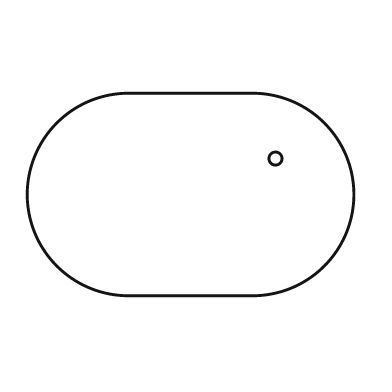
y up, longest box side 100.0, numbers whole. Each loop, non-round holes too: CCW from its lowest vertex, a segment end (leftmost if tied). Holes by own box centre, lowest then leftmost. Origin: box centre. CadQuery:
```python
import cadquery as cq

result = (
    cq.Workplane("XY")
    .moveTo(-19.0, -31.0)
    .lineTo(19.0, -31.0)
    .threePointArc((50.0, 0.0), (19.0, 31.0))
    .lineTo(-19.0, 31.0)
    .threePointArc((-50.0, 0.0), (-19.0, -31.0))
    .close()
    .moveTo(26.0, 11.0)
    .circle(2.0)
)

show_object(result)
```